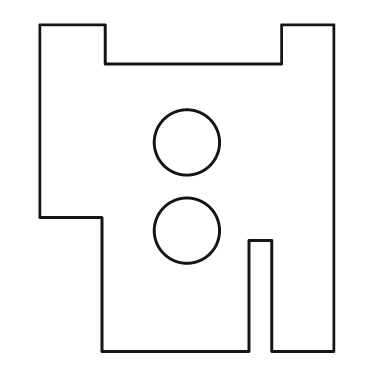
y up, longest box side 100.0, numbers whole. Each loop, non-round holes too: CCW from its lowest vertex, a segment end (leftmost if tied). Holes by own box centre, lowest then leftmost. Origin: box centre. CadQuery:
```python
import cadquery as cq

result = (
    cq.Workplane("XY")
    .moveTo(-26.0, -50.0)
    .lineTo(19.0, -50.0)
    .lineTo(19.0, -16.0)
    .lineTo(26.0, -16.0)
    .lineTo(26.0, -50.0)
    .lineTo(45.0, -50.0)
    .lineTo(45.0, 50.0)
    .lineTo(29.0, 50.0)
    .lineTo(29.0, 38.0)
    .lineTo(-25.0, 38.0)
    .lineTo(-25.0, 50.0)
    .lineTo(-45.0, 50.0)
    .lineTo(-45.0, -9.0)
    .lineTo(-26.0, -9.0)
    .close()
    .moveTo(0.0, -13.0)
    .circle(10.0)
    .moveTo(0.0, 14.0)
    .circle(10.0)
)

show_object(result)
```